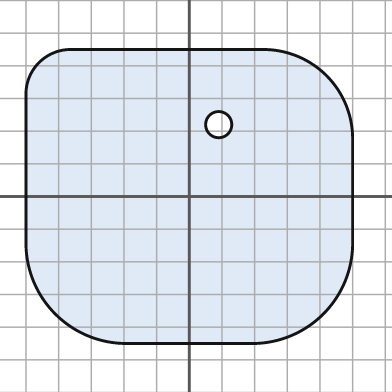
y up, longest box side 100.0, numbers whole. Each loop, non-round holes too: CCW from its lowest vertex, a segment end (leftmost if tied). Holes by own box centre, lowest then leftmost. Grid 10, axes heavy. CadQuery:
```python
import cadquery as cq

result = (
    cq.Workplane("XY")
    .moveTo(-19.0, -45.0)
    .lineTo(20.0, -45.0)
    .threePointArc((41.0, -36.0), (50.0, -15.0))
    .lineTo(50.0, 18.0)
    .threePointArc((42.0, 37.0), (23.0, 45.0))
    .lineTo(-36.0, 45.0)
    .threePointArc((-46.0, 41.0), (-50.0, 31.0))
    .lineTo(-50.0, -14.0)
    .threePointArc((-41.0, -36.0), (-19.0, -45.0))
    .close()
    .moveTo(9.0, 22.0)
    .circle(4.0)
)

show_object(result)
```